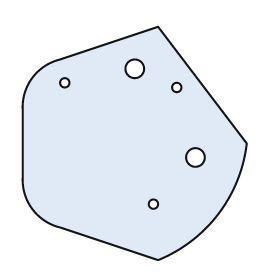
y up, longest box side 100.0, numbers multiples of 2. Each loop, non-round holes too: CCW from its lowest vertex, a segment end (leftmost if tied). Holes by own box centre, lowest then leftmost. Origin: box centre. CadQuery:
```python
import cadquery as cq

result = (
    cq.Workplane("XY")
    .moveTo(10.0, -50.0)
    .threePointArc((36.0, -30.0), (48.0, 0.0))
    .lineTo(10.0, 50.0)
    .lineTo(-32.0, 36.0)
    .threePointArc((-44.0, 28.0), (-48.0, 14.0))
    .lineTo(-48.0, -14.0)
    .threePointArc((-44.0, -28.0), (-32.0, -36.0))
    .close()
    .moveTo(8.0, -26.0)
    .circle(2.0)
    .moveTo(26.0, -6.0)
    .circle(4.0)
    .moveTo(18.0, 24.0)
    .circle(2.0)
    .moveTo(-30.0, 26.0)
    .circle(2.0)
    .moveTo(0.0, 32.0)
    .circle(4.0)
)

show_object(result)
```